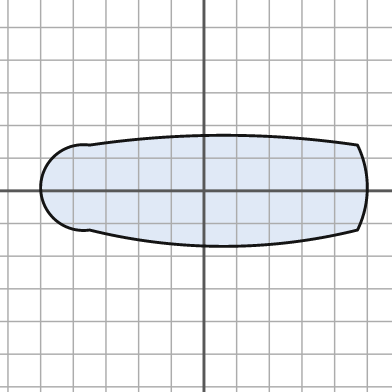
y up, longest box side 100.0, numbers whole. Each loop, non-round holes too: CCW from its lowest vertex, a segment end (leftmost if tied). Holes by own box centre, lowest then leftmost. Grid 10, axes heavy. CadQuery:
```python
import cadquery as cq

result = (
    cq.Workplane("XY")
    .moveTo(-35.0, -12.0)
    .threePointArc((6.0, -17.0), (47.0, -12.0))
    .threePointArc((50.0, 1.0), (47.0, 14.0))
    .threePointArc((6.0, 17.0), (-35.0, 14.0))
    .threePointArc((-50.0, 1.0), (-35.0, -12.0))
    .close()
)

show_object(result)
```